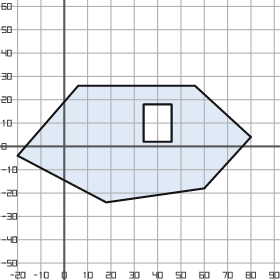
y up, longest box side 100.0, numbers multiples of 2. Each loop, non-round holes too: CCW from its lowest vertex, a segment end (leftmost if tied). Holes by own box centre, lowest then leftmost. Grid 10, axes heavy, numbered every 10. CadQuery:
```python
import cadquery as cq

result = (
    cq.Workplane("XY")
    .moveTo(18.0, -24.0)
    .lineTo(60.0, -18.0)
    .lineTo(80.0, 4.0)
    .lineTo(56.0, 26.0)
    .lineTo(6.0, 26.0)
    .lineTo(-20.0, -4.0)
    .close()
    .moveTo(34.0, 2.0)
    .lineTo(46.0, 2.0)
    .lineTo(46.0, 18.0)
    .lineTo(34.0, 18.0)
    .close()
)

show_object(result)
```